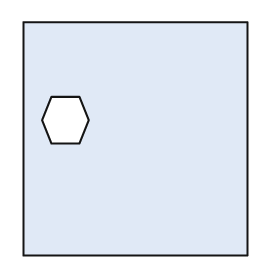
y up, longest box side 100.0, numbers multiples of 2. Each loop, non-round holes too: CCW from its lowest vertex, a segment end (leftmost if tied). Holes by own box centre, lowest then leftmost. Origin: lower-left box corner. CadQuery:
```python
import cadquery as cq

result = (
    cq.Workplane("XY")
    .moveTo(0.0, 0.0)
    .lineTo(96.0, 0.0)
    .lineTo(96.0, 100.0)
    .lineTo(0.0, 100.0)
    .close()
    .moveTo(12.0, 48.0)
    .lineTo(24.0, 48.0)
    .lineTo(28.0, 58.0)
    .lineTo(24.0, 68.0)
    .lineTo(12.0, 68.0)
    .lineTo(8.0, 58.0)
    .close()
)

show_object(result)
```